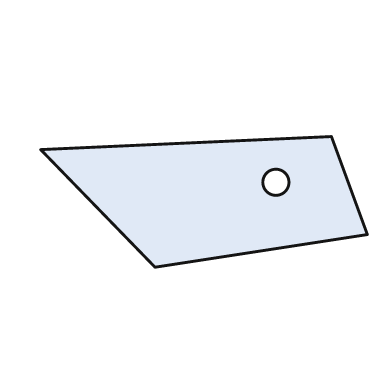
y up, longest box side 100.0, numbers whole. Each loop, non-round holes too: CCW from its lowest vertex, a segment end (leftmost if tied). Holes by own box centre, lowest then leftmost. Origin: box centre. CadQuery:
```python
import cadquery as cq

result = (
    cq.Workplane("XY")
    .moveTo(-15.0, -20.0)
    .lineTo(50.0, -10.0)
    .lineTo(39.0, 20.0)
    .lineTo(-50.0, 16.0)
    .close()
    .moveTo(22.0, 6.0)
    .circle(4.0)
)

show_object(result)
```